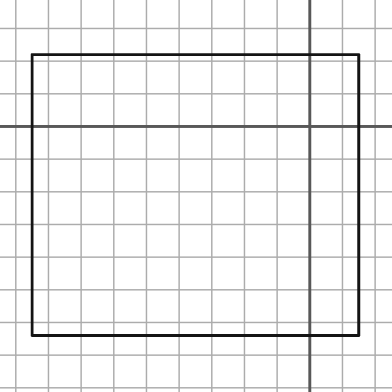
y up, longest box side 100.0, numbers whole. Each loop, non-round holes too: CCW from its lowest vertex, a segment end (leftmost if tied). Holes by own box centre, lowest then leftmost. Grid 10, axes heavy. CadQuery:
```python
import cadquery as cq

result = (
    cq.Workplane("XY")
    .moveTo(-85.0, -64.0)
    .lineTo(15.0, -64.0)
    .lineTo(15.0, 22.0)
    .lineTo(-85.0, 22.0)
    .close()
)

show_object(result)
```